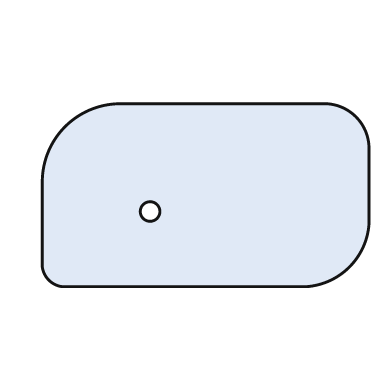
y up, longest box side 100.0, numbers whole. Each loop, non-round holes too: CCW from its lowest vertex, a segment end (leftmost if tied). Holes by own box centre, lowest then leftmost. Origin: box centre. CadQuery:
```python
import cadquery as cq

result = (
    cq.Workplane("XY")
    .moveTo(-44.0, -28.0)
    .lineTo(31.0, -28.0)
    .threePointArc((44.0, -22.0), (50.0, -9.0))
    .lineTo(50.0, 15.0)
    .threePointArc((46.0, 24.0), (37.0, 28.0))
    .lineTo(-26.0, 28.0)
    .threePointArc((-43.0, 21.0), (-50.0, 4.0))
    .lineTo(-50.0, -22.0)
    .threePointArc((-48.0, -26.0), (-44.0, -28.0))
    .close()
    .moveTo(-17.0, -5.0)
    .circle(3.0)
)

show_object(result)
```